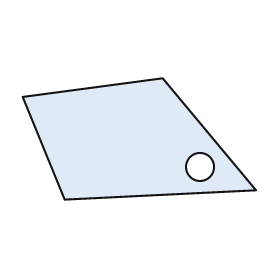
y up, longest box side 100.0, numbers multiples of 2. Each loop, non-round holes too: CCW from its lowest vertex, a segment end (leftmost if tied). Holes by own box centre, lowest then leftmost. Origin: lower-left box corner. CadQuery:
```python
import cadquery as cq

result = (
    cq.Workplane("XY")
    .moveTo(18.0, 0.0)
    .lineTo(100.0, 4.0)
    .lineTo(60.0, 52.0)
    .lineTo(0.0, 44.0)
    .close()
    .moveTo(76.0, 14.0)
    .circle(6.0)
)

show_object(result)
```